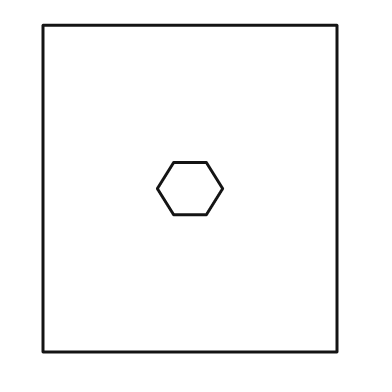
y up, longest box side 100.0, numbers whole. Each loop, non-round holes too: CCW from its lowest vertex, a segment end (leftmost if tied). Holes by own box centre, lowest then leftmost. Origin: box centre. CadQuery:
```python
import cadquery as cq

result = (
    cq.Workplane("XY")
    .moveTo(-45.0, -50.0)
    .lineTo(45.0, -50.0)
    .lineTo(45.0, 50.0)
    .lineTo(-45.0, 50.0)
    .close()
    .moveTo(-5.0, -8.0)
    .lineTo(5.0, -8.0)
    .lineTo(10.0, 0.0)
    .lineTo(5.0, 8.0)
    .lineTo(-5.0, 8.0)
    .lineTo(-10.0, 0.0)
    .close()
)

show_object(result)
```